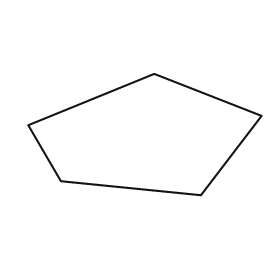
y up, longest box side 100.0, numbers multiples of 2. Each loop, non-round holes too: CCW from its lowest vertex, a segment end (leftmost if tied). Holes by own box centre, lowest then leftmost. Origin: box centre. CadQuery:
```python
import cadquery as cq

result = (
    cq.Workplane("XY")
    .moveTo(24.0, -26.0)
    .lineTo(50.0, 8.0)
    .lineTo(4.0, 26.0)
    .lineTo(-50.0, 4.0)
    .lineTo(-36.0, -20.0)
    .close()
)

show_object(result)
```